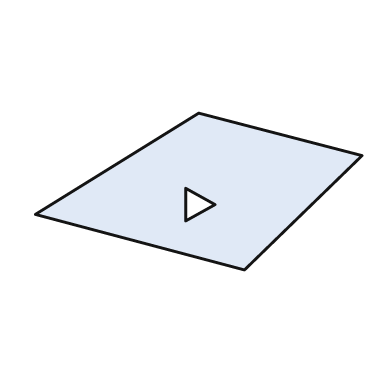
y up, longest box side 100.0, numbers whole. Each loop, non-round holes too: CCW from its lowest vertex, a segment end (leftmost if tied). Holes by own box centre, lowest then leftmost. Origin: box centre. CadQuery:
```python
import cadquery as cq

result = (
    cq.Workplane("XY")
    .moveTo(14.0, -24.0)
    .lineTo(50.0, 11.0)
    .lineTo(0.0, 24.0)
    .lineTo(-50.0, -7.0)
    .close()
    .moveTo(-4.0, -9.0)
    .lineTo(5.0, -4.0)
    .lineTo(-4.0, 1.0)
    .close()
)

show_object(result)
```